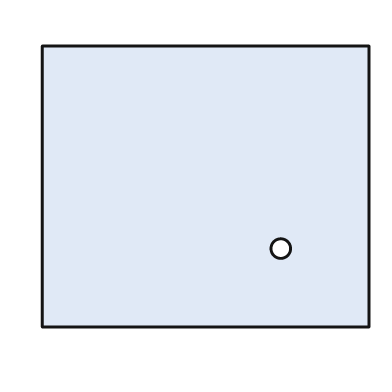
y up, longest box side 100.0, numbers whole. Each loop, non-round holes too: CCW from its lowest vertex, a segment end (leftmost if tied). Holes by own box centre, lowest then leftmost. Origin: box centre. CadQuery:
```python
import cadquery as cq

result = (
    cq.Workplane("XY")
    .moveTo(-50.0, -43.0)
    .lineTo(50.0, -43.0)
    .lineTo(50.0, 43.0)
    .lineTo(-50.0, 43.0)
    .close()
    .moveTo(23.0, -19.0)
    .circle(3.0)
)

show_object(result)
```